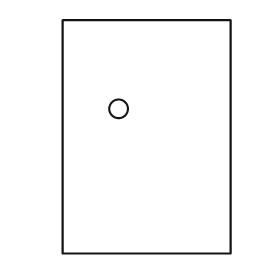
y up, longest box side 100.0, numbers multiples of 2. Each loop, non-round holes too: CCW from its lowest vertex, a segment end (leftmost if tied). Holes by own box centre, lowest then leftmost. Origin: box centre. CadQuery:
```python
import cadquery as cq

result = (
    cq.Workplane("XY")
    .moveTo(-36.0, -50.0)
    .lineTo(36.0, -50.0)
    .lineTo(36.0, 50.0)
    .lineTo(-36.0, 50.0)
    .close()
    .moveTo(-12.0, 12.0)
    .circle(4.0)
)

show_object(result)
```